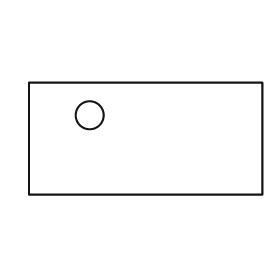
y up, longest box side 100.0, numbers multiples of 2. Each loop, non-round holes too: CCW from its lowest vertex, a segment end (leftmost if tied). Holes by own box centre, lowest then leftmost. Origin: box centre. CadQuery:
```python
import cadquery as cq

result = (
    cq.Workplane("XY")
    .moveTo(-50.0, -24.0)
    .lineTo(50.0, -24.0)
    .lineTo(50.0, 24.0)
    .lineTo(-50.0, 24.0)
    .close()
    .moveTo(-24.0, 10.0)
    .circle(6.0)
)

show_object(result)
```